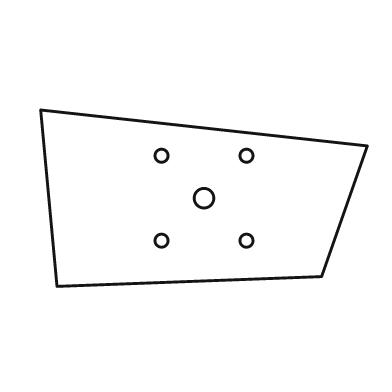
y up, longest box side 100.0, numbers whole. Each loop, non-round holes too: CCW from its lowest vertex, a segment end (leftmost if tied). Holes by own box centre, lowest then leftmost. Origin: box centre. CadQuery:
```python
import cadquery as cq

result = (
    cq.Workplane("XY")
    .moveTo(-45.0, -27.0)
    .lineTo(36.0, -24.0)
    .lineTo(50.0, 16.0)
    .lineTo(-50.0, 27.0)
    .close()
    .moveTo(-13.0, -13.0)
    .circle(2.0)
    .moveTo(13.0, -13.0)
    .circle(2.0)
    .moveTo(0.0, 0.0)
    .circle(3.0)
    .moveTo(-13.0, 13.0)
    .circle(2.0)
    .moveTo(13.0, 13.0)
    .circle(2.0)
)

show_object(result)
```